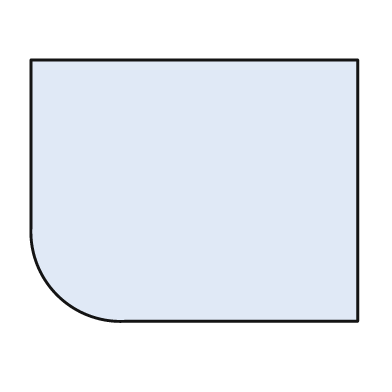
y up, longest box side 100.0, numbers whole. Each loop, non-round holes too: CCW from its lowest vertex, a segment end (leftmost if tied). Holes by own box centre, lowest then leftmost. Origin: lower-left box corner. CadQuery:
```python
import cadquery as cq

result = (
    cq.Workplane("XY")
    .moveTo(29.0, 0.0)
    .lineTo(100.0, 0.0)
    .lineTo(100.0, 80.0)
    .lineTo(0.0, 80.0)
    .lineTo(0.0, 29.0)
    .threePointArc((8.0, 8.0), (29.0, 0.0))
    .close()
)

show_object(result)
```